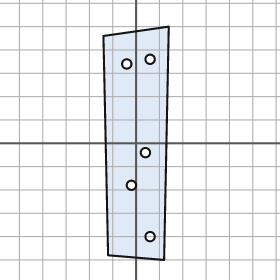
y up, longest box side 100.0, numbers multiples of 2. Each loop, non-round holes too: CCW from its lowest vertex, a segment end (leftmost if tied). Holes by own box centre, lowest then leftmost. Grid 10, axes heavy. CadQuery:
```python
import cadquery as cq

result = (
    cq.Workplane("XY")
    .moveTo(12.0, -50.0)
    .lineTo(14.0, 50.0)
    .lineTo(-14.0, 46.0)
    .lineTo(-12.0, -48.0)
    .close()
    .moveTo(6.0, -40.0)
    .circle(2.0)
    .moveTo(-2.0, -18.0)
    .circle(2.0)
    .moveTo(4.0, -4.0)
    .circle(2.0)
    .moveTo(-4.0, 34.0)
    .circle(2.0)
    .moveTo(6.0, 36.0)
    .circle(2.0)
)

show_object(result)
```